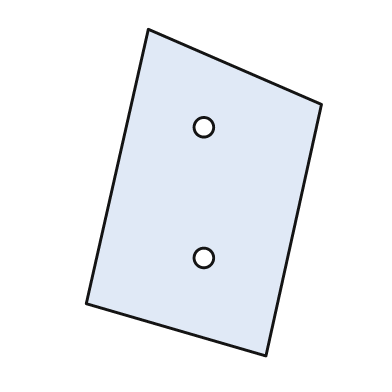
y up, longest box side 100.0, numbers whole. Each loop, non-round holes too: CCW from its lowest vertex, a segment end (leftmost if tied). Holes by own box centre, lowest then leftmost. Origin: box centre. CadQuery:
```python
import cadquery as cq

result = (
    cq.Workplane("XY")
    .moveTo(19.0, -50.0)
    .lineTo(36.0, 27.0)
    .lineTo(-17.0, 50.0)
    .lineTo(-36.0, -34.0)
    .close()
    .moveTo(0.0, -20.0)
    .circle(3.0)
    .moveTo(0.0, 20.0)
    .circle(3.0)
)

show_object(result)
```